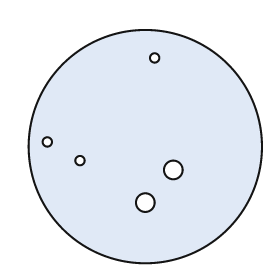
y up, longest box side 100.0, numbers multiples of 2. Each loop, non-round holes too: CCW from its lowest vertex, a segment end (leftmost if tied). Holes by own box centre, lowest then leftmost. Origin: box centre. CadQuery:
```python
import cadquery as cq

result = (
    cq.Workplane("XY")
    .moveTo(0.0, 0.0)
    .circle(50.0)
    .moveTo(0.0, -24.0)
    .circle(4.0)
    .moveTo(12.0, -10.0)
    .circle(4.0)
    .moveTo(-28.0, -6.0)
    .circle(2.0)
    .moveTo(-42.0, 2.0)
    .circle(2.0)
    .moveTo(4.0, 38.0)
    .circle(2.0)
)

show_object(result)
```